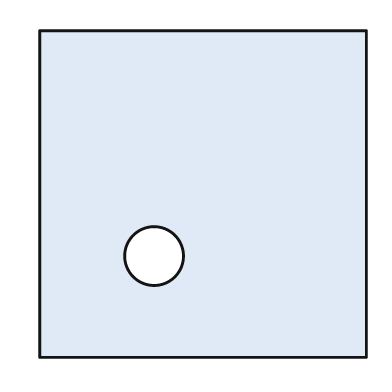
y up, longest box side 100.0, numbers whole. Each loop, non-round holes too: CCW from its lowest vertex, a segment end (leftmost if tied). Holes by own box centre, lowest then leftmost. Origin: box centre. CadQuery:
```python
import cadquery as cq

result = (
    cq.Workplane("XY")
    .moveTo(-50.0, -50.0)
    .lineTo(50.0, -50.0)
    .lineTo(50.0, 50.0)
    .lineTo(-50.0, 50.0)
    .close()
    .moveTo(-15.0, -19.0)
    .circle(9.0)
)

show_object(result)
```